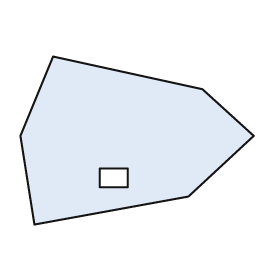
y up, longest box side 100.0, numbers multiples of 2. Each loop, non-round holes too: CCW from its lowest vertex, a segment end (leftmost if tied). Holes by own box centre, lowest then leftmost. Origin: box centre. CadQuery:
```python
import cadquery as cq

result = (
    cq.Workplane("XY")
    .moveTo(-44.0, -36.0)
    .lineTo(22.0, -24.0)
    .lineTo(50.0, 2.0)
    .lineTo(28.0, 22.0)
    .lineTo(-36.0, 36.0)
    .lineTo(-50.0, 2.0)
    .close()
    .moveTo(-16.0, -20.0)
    .lineTo(-4.0, -20.0)
    .lineTo(-4.0, -12.0)
    .lineTo(-16.0, -12.0)
    .close()
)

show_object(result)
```